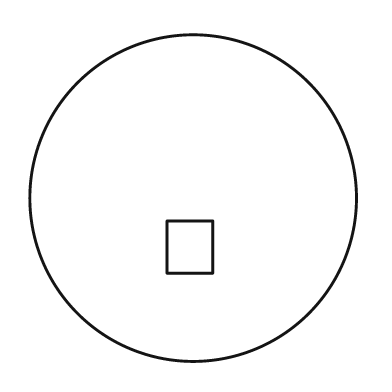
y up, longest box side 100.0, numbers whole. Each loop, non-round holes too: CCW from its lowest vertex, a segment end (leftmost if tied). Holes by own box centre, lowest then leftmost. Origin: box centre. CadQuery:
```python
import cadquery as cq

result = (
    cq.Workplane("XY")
    .moveTo(0.0, 0.0)
    .circle(50.0)
    .moveTo(-8.0, -23.0)
    .lineTo(6.0, -23.0)
    .lineTo(6.0, -7.0)
    .lineTo(-8.0, -7.0)
    .close()
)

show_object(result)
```